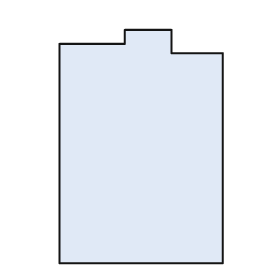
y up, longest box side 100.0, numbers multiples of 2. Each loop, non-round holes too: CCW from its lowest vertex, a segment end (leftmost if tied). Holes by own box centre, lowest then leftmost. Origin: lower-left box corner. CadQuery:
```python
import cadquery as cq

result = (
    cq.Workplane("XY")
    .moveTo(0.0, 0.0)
    .lineTo(70.0, 0.0)
    .lineTo(70.0, 90.0)
    .lineTo(48.0, 90.0)
    .lineTo(48.0, 100.0)
    .lineTo(28.0, 100.0)
    .lineTo(28.0, 94.0)
    .lineTo(0.0, 94.0)
    .close()
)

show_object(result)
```